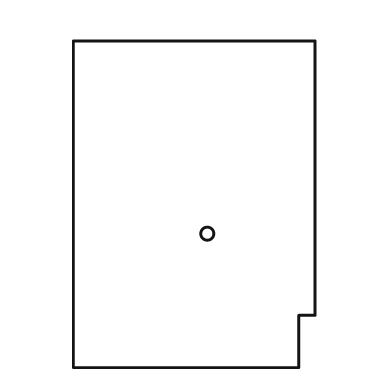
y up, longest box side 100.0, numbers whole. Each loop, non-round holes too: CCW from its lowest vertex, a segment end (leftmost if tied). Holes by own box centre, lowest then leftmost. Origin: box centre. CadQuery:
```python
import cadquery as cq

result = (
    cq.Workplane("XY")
    .moveTo(-37.0, -50.0)
    .lineTo(32.0, -50.0)
    .lineTo(32.0, -34.0)
    .lineTo(37.0, -34.0)
    .lineTo(37.0, 50.0)
    .lineTo(-37.0, 50.0)
    .close()
    .moveTo(4.0, -9.0)
    .circle(2.0)
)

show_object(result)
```